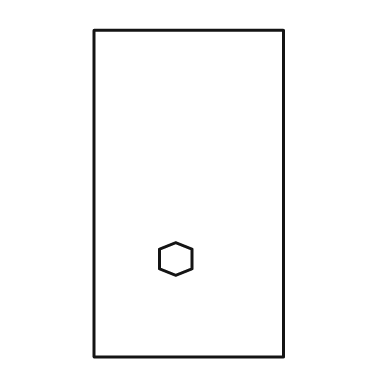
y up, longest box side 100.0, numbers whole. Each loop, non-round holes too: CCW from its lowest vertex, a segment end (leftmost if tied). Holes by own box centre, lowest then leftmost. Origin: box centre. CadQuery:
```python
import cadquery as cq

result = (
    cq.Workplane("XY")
    .moveTo(-29.0, -50.0)
    .lineTo(29.0, -50.0)
    .lineTo(29.0, 50.0)
    .lineTo(-29.0, 50.0)
    .close()
    .moveTo(-4.0, -25.0)
    .lineTo(1.0, -23.0)
    .lineTo(1.0, -17.0)
    .lineTo(-4.0, -15.0)
    .lineTo(-9.0, -17.0)
    .lineTo(-9.0, -23.0)
    .close()
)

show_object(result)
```